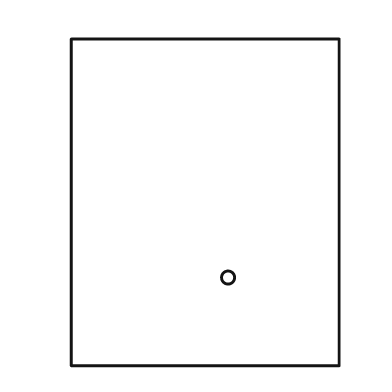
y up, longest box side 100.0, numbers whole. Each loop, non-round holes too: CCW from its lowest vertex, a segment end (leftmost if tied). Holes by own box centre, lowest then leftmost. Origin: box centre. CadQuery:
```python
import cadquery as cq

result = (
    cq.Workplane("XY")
    .moveTo(-41.0, -50.0)
    .lineTo(41.0, -50.0)
    .lineTo(41.0, 50.0)
    .lineTo(-41.0, 50.0)
    .close()
    .moveTo(7.0, -23.0)
    .circle(2.0)
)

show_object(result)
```